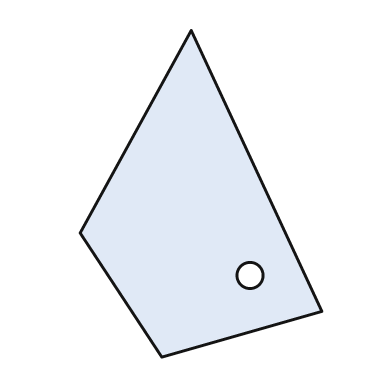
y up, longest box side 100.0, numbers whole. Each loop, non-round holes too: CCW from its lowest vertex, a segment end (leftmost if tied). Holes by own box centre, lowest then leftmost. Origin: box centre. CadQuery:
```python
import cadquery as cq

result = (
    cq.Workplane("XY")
    .moveTo(-12.0, -50.0)
    .lineTo(37.0, -36.0)
    .lineTo(-3.0, 50.0)
    .lineTo(-37.0, -12.0)
    .close()
    .moveTo(15.0, -25.0)
    .circle(4.0)
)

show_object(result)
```